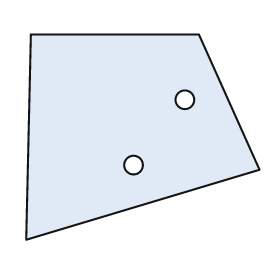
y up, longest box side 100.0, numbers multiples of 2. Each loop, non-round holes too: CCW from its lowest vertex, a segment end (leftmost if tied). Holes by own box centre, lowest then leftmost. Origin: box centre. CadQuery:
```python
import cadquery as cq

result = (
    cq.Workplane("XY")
    .moveTo(-50.0, -44.0)
    .lineTo(50.0, -14.0)
    .lineTo(24.0, 44.0)
    .lineTo(-48.0, 44.0)
    .close()
    .moveTo(-4.0, -12.0)
    .circle(4.0)
    .moveTo(18.0, 16.0)
    .circle(4.0)
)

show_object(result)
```